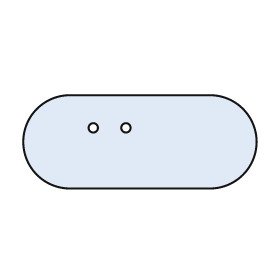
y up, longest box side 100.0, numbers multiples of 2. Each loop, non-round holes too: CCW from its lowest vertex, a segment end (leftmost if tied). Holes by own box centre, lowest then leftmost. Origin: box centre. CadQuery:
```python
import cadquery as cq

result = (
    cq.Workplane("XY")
    .moveTo(-30.0, -20.0)
    .lineTo(30.0, -20.0)
    .threePointArc((50.0, 0.0), (30.0, 20.0))
    .lineTo(-30.0, 20.0)
    .threePointArc((-50.0, 0.0), (-30.0, -20.0))
    .close()
    .moveTo(-20.0, 6.0)
    .circle(2.0)
    .moveTo(-6.0, 6.0)
    .circle(2.0)
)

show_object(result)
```